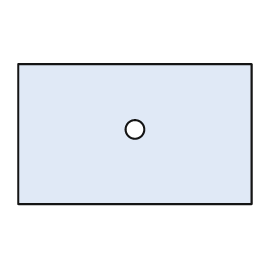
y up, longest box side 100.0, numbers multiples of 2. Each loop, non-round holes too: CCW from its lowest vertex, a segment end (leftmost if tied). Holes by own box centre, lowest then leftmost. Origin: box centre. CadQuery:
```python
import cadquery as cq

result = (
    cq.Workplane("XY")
    .moveTo(-50.0, -30.0)
    .lineTo(50.0, -30.0)
    .lineTo(50.0, 30.0)
    .lineTo(-50.0, 30.0)
    .close()
    .moveTo(0.0, 2.0)
    .circle(4.0)
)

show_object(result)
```